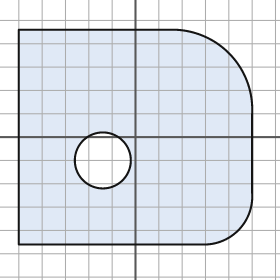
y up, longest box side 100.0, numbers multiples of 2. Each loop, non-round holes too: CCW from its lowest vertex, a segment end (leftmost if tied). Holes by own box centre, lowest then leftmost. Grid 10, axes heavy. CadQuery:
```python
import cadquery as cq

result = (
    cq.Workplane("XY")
    .moveTo(-50.0, -46.0)
    .lineTo(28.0, -46.0)
    .threePointArc((44.0, -40.0), (50.0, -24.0))
    .lineTo(50.0, 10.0)
    .threePointArc((40.0, 36.0), (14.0, 46.0))
    .lineTo(-50.0, 46.0)
    .close()
    .moveTo(-14.0, -10.0)
    .circle(12.0)
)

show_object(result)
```